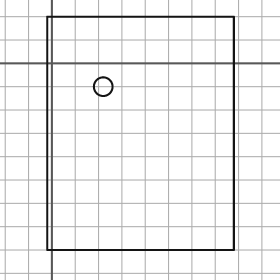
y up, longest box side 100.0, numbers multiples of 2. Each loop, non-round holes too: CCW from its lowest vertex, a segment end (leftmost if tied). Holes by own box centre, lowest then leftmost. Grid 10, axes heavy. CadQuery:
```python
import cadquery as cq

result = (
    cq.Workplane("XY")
    .moveTo(-2.0, -80.0)
    .lineTo(78.0, -80.0)
    .lineTo(78.0, 20.0)
    .lineTo(-2.0, 20.0)
    .close()
    .moveTo(22.0, -10.0)
    .circle(4.0)
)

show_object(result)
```